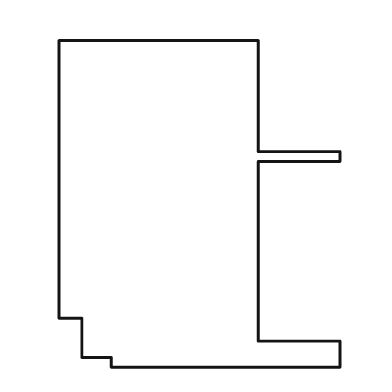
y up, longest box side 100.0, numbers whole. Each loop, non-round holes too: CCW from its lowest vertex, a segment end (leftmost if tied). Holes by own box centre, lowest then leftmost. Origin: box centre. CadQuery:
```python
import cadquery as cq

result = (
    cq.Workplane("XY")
    .moveTo(-27.0, -50.0)
    .lineTo(43.0, -50.0)
    .lineTo(43.0, -42.0)
    .lineTo(18.0, -42.0)
    .lineTo(18.0, 13.0)
    .lineTo(43.0, 13.0)
    .lineTo(43.0, 16.0)
    .lineTo(18.0, 16.0)
    .lineTo(18.0, 50.0)
    .lineTo(-43.0, 50.0)
    .lineTo(-43.0, -35.0)
    .lineTo(-36.0, -35.0)
    .lineTo(-36.0, -47.0)
    .lineTo(-27.0, -47.0)
    .close()
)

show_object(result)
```